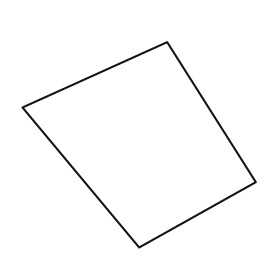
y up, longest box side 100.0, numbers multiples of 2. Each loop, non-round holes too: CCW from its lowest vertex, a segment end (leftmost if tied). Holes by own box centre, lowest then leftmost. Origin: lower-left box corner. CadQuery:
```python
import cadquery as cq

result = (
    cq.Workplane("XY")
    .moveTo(50.0, 0.0)
    .lineTo(100.0, 28.0)
    .lineTo(62.0, 88.0)
    .lineTo(0.0, 60.0)
    .close()
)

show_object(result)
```